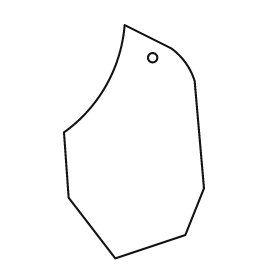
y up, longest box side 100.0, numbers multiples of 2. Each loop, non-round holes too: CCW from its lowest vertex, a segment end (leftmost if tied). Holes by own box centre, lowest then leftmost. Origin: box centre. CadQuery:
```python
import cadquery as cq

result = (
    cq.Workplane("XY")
    .moveTo(-8.0, -50.0)
    .lineTo(22.0, -40.0)
    .lineTo(30.0, -20.0)
    .lineTo(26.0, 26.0)
    .threePointArc((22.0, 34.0), (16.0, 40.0))
    .lineTo(-4.0, 50.0)
    .threePointArc((-12.0, 24.0), (-30.0, 4.0))
    .lineTo(-28.0, -24.0)
    .close()
    .moveTo(8.0, 36.0)
    .circle(2.0)
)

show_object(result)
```